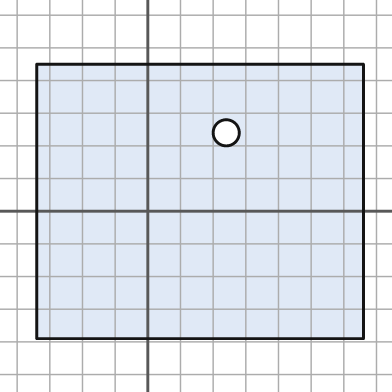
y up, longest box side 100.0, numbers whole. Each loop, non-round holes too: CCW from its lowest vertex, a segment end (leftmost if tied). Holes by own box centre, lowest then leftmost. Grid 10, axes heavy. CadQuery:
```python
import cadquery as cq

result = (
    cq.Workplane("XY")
    .moveTo(-34.0, -39.0)
    .lineTo(66.0, -39.0)
    .lineTo(66.0, 45.0)
    .lineTo(-34.0, 45.0)
    .close()
    .moveTo(24.0, 24.0)
    .circle(4.0)
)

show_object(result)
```